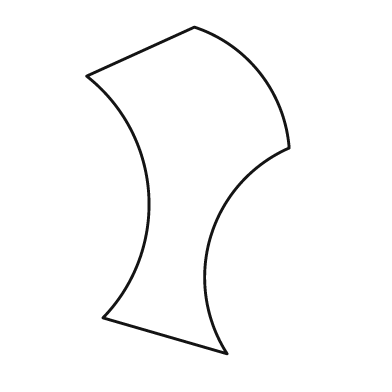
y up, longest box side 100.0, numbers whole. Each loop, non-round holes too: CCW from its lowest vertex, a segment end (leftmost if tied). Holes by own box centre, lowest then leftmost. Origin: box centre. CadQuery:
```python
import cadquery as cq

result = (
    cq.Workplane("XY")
    .moveTo(12.0, -50.0)
    .threePointArc((7.0, -14.0), (31.0, 13.0))
    .threePointArc((22.0, 36.0), (2.0, 50.0))
    .lineTo(-31.0, 35.0)
    .threePointArc((-12.0, -1.0), (-26.0, -39.0))
    .close()
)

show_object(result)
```